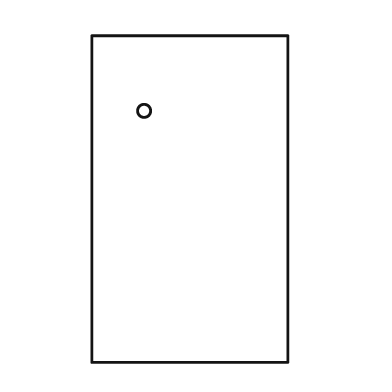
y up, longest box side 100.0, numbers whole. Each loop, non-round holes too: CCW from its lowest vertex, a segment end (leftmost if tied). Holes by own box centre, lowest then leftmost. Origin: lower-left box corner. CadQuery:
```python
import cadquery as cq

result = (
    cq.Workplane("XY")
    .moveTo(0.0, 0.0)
    .lineTo(60.0, 0.0)
    .lineTo(60.0, 100.0)
    .lineTo(0.0, 100.0)
    .close()
    .moveTo(16.0, 77.0)
    .circle(2.0)
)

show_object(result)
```